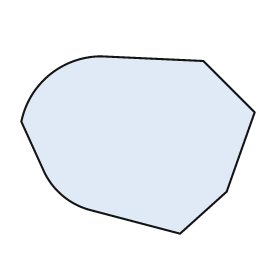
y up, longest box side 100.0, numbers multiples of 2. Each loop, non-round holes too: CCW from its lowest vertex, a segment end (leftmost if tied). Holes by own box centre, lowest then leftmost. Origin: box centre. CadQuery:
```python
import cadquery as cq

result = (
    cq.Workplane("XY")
    .moveTo(18.0, -38.0)
    .lineTo(38.0, -20.0)
    .lineTo(50.0, 14.0)
    .lineTo(28.0, 36.0)
    .lineTo(-16.0, 38.0)
    .threePointArc((-38.0, 30.0), (-50.0, 10.0))
    .lineTo(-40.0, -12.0)
    .threePointArc((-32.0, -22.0), (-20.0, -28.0))
    .close()
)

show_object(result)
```